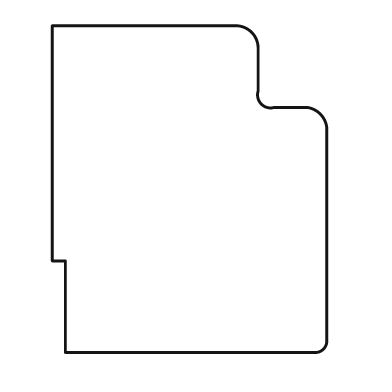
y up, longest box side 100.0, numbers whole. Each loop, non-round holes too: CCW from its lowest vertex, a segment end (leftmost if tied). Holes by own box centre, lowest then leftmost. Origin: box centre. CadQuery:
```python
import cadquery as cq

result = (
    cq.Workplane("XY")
    .moveTo(-38.0, -50.0)
    .lineTo(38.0, -50.0)
    .threePointArc((41.0, -49.0), (42.0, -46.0))
    .lineTo(42.0, 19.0)
    .threePointArc((40.0, 23.0), (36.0, 25.0))
    .lineTo(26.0, 25.0)
    .threePointArc((22.0, 26.0), (21.0, 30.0))
    .lineTo(21.0, 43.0)
    .threePointArc((19.0, 48.0), (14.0, 50.0))
    .lineTo(-42.0, 50.0)
    .lineTo(-42.0, -22.0)
    .lineTo(-38.0, -22.0)
    .close()
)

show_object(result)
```